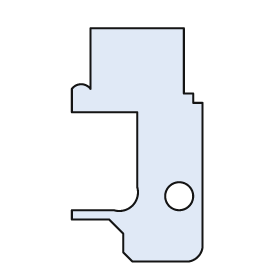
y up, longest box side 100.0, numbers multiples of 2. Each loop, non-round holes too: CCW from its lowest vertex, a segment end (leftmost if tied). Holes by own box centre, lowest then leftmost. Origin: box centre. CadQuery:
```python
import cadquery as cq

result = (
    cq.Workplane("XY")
    .moveTo(-2.0, -50.0)
    .lineTo(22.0, -50.0)
    .threePointArc((26.0, -48.0), (28.0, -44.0))
    .lineTo(28.0, 18.0)
    .lineTo(24.0, 18.0)
    .lineTo(24.0, 22.0)
    .lineTo(20.0, 22.0)
    .lineTo(20.0, 50.0)
    .lineTo(-20.0, 50.0)
    .lineTo(-20.0, 24.0)
    .threePointArc((-24.0, 26.0), (-28.0, 24.0))
    .lineTo(-28.0, 14.0)
    .lineTo(0.0, 14.0)
    .lineTo(0.0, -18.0)
    .threePointArc((-2.0, -26.0), (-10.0, -28.0))
    .lineTo(-28.0, -28.0)
    .lineTo(-28.0, -32.0)
    .lineTo(-12.0, -32.0)
    .lineTo(-6.0, -38.0)
    .lineTo(-6.0, -46.0)
    .close()
    .moveTo(18.0, -22.0)
    .circle(6.0)
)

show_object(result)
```